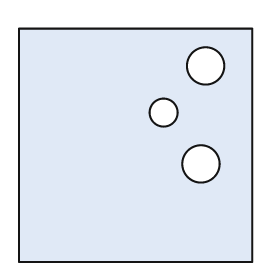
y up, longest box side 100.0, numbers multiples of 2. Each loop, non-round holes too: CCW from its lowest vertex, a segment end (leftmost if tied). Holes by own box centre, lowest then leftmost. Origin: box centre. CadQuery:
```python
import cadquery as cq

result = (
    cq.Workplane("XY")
    .moveTo(-50.0, -50.0)
    .lineTo(50.0, -50.0)
    .lineTo(50.0, 50.0)
    .lineTo(-50.0, 50.0)
    .close()
    .moveTo(28.0, -8.0)
    .circle(8.0)
    .moveTo(12.0, 14.0)
    .circle(6.0)
    .moveTo(30.0, 34.0)
    .circle(8.0)
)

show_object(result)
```